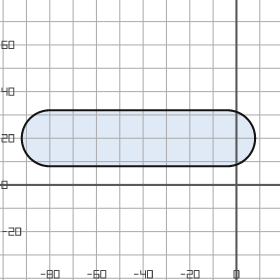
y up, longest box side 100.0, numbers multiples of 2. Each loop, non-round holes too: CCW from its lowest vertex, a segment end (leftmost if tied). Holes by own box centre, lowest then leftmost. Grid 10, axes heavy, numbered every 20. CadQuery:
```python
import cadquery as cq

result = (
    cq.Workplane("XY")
    .moveTo(-80.0, 8.0)
    .lineTo(-4.0, 8.0)
    .threePointArc((8.0, 20.0), (-4.0, 32.0))
    .lineTo(-80.0, 32.0)
    .threePointArc((-92.0, 20.0), (-80.0, 8.0))
    .close()
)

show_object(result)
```